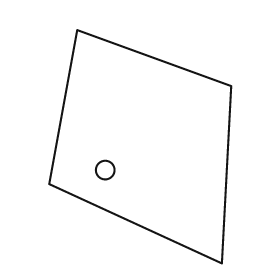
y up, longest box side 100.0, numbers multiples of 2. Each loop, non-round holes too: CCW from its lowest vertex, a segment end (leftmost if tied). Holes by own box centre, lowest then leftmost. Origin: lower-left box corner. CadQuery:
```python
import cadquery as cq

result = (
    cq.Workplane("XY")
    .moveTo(74.0, 0.0)
    .lineTo(78.0, 76.0)
    .lineTo(12.0, 100.0)
    .lineTo(0.0, 34.0)
    .close()
    .moveTo(24.0, 40.0)
    .circle(4.0)
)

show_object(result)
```